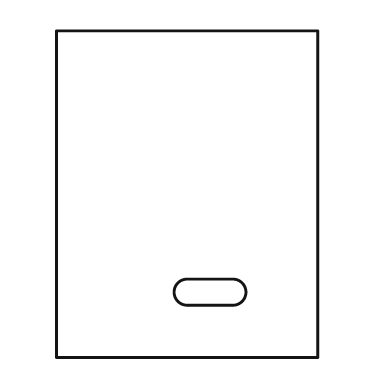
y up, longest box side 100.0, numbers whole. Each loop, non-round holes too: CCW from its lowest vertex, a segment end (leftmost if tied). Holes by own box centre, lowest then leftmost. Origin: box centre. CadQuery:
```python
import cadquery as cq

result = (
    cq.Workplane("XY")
    .moveTo(-40.0, -50.0)
    .lineTo(40.0, -50.0)
    .lineTo(40.0, 50.0)
    .lineTo(-40.0, 50.0)
    .close()
    .moveTo(0.0, -34.0)
    .lineTo(14.0, -34.0)
    .threePointArc((18.0, -30.0), (14.0, -26.0))
    .lineTo(0.0, -26.0)
    .threePointArc((-4.0, -30.0), (0.0, -34.0))
    .close()
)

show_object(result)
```